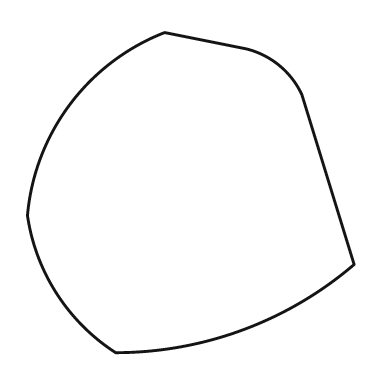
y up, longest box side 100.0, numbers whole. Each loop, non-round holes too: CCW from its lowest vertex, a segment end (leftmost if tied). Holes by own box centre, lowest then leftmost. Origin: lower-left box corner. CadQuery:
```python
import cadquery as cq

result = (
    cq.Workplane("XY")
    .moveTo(27.0, 0.0)
    .threePointArc((66.0, 7.0), (100.0, 27.0))
    .lineTo(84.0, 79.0)
    .threePointArc((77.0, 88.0), (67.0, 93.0))
    .lineTo(42.0, 98.0)
    .threePointArc((13.0, 76.0), (0.0, 42.0))
    .threePointArc((9.0, 18.0), (27.0, 0.0))
    .close()
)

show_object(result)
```